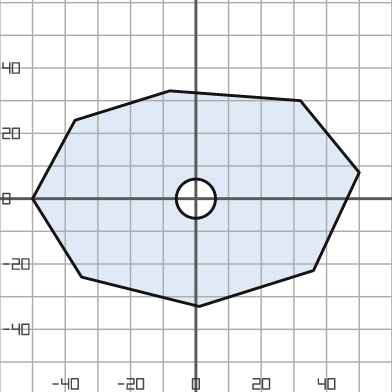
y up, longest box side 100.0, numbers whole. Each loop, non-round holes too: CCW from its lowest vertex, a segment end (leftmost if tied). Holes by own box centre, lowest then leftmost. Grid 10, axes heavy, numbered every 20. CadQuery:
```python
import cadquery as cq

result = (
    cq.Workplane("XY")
    .moveTo(1.0, -33.0)
    .lineTo(36.0, -22.0)
    .lineTo(50.0, 8.0)
    .lineTo(32.0, 30.0)
    .lineTo(-8.0, 33.0)
    .lineTo(-37.0, 24.0)
    .lineTo(-50.0, 0.0)
    .lineTo(-35.0, -24.0)
    .close()
    .moveTo(0.0, 0.0)
    .circle(6.0)
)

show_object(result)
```